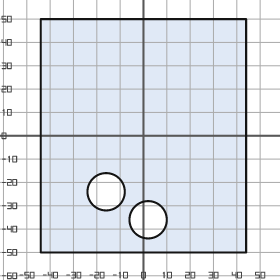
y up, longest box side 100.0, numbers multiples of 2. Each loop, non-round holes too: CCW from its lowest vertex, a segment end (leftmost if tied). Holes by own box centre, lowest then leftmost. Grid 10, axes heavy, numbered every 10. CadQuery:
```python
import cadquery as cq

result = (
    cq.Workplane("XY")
    .moveTo(-44.0, -50.0)
    .lineTo(44.0, -50.0)
    .lineTo(44.0, 50.0)
    .lineTo(-44.0, 50.0)
    .close()
    .moveTo(2.0, -36.0)
    .circle(8.0)
    .moveTo(-16.0, -24.0)
    .circle(8.0)
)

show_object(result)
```